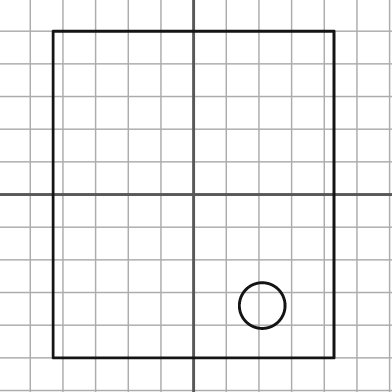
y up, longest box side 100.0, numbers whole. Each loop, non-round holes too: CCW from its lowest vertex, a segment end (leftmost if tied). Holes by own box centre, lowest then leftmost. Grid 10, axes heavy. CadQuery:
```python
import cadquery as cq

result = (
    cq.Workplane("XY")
    .moveTo(-43.0, -50.0)
    .lineTo(43.0, -50.0)
    .lineTo(43.0, 50.0)
    .lineTo(-43.0, 50.0)
    .close()
    .moveTo(21.0, -34.0)
    .circle(7.0)
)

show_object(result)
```